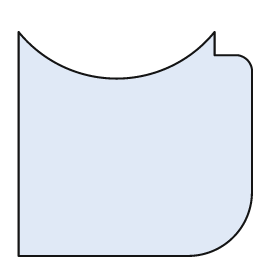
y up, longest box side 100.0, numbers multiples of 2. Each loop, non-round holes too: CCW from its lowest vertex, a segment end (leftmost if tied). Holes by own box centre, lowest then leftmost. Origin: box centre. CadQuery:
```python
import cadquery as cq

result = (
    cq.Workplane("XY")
    .moveTo(-50.0, -48.0)
    .lineTo(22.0, -48.0)
    .threePointArc((42.0, -40.0), (50.0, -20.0))
    .lineTo(50.0, 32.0)
    .threePointArc((48.0, 36.0), (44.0, 38.0))
    .lineTo(34.0, 38.0)
    .lineTo(34.0, 48.0)
    .threePointArc((-8.0, 28.0), (-50.0, 48.0))
    .close()
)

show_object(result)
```